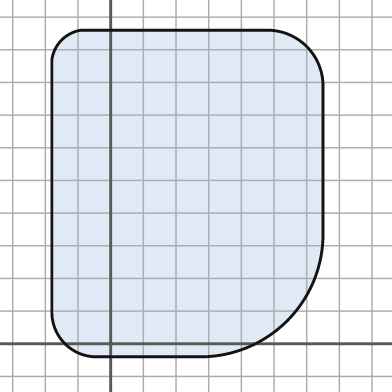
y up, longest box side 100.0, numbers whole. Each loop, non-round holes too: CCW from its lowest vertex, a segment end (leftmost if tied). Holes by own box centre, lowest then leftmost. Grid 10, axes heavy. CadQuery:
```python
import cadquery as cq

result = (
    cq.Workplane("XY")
    .moveTo(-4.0, -4.0)
    .lineTo(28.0, -4.0)
    .threePointArc((54.0, 7.0), (65.0, 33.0))
    .lineTo(65.0, 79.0)
    .threePointArc((60.0, 91.0), (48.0, 96.0))
    .lineTo(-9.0, 96.0)
    .threePointArc((-15.0, 93.0), (-18.0, 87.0))
    .lineTo(-18.0, 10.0)
    .threePointArc((-14.0, 0.0), (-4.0, -4.0))
    .close()
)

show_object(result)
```